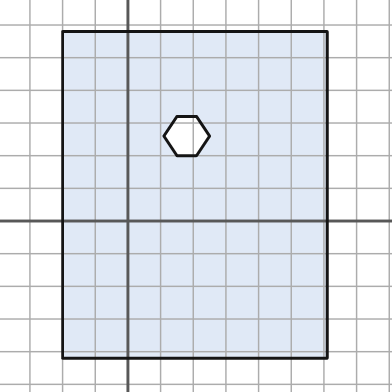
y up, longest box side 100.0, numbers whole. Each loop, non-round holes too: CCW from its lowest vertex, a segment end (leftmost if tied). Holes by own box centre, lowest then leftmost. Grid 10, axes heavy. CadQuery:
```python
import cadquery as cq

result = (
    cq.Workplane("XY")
    .moveTo(-20.0, -42.0)
    .lineTo(61.0, -42.0)
    .lineTo(61.0, 58.0)
    .lineTo(-20.0, 58.0)
    .close()
    .moveTo(15.0, 20.0)
    .lineTo(21.0, 20.0)
    .lineTo(25.0, 26.0)
    .lineTo(21.0, 32.0)
    .lineTo(15.0, 32.0)
    .lineTo(11.0, 26.0)
    .close()
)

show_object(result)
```